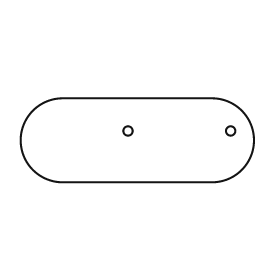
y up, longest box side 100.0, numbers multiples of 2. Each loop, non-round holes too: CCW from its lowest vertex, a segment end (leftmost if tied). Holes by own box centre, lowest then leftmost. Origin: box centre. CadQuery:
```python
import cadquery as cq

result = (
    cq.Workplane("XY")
    .moveTo(-32.0, -18.0)
    .lineTo(32.0, -18.0)
    .threePointArc((50.0, 0.0), (32.0, 18.0))
    .lineTo(-32.0, 18.0)
    .threePointArc((-50.0, 0.0), (-32.0, -18.0))
    .close()
    .moveTo(-4.0, 4.0)
    .circle(2.0)
    .moveTo(40.0, 4.0)
    .circle(2.0)
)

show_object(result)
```